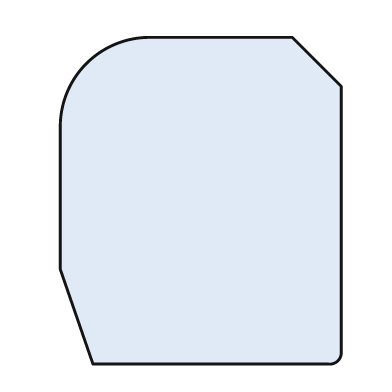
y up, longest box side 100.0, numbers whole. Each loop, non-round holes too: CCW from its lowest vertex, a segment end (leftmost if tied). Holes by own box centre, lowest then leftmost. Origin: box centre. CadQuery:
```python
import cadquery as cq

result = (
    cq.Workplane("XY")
    .moveTo(-33.0, -50.0)
    .lineTo(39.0, -50.0)
    .threePointArc((42.0, -49.0), (43.0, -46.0))
    .lineTo(43.0, 35.0)
    .lineTo(28.0, 50.0)
    .lineTo(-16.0, 50.0)
    .threePointArc((-35.0, 42.0), (-43.0, 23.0))
    .lineTo(-43.0, -21.0)
    .close()
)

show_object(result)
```